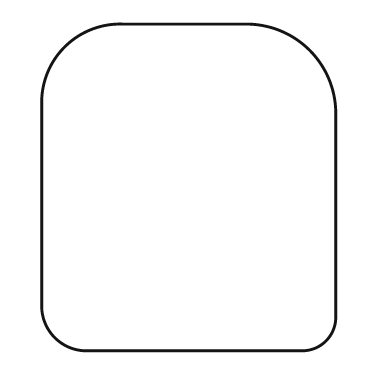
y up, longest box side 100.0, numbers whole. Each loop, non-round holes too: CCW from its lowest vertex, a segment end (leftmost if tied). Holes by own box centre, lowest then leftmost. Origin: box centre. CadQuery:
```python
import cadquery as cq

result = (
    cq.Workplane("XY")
    .moveTo(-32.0, -50.0)
    .lineTo(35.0, -50.0)
    .threePointArc((42.0, -47.0), (45.0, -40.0))
    .lineTo(45.0, 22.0)
    .threePointArc((37.0, 42.0), (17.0, 50.0))
    .lineTo(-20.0, 50.0)
    .threePointArc((-38.0, 43.0), (-45.0, 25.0))
    .lineTo(-45.0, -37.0)
    .threePointArc((-41.0, -46.0), (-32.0, -50.0))
    .close()
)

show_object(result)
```